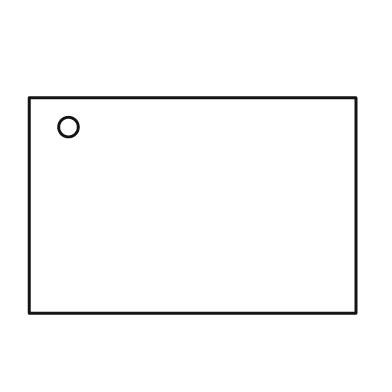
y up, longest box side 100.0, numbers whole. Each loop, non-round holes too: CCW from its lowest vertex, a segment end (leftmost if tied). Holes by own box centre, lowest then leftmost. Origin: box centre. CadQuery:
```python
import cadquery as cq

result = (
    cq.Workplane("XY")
    .moveTo(-50.0, -33.0)
    .lineTo(50.0, -33.0)
    .lineTo(50.0, 33.0)
    .lineTo(-50.0, 33.0)
    .close()
    .moveTo(-38.0, 24.0)
    .circle(3.0)
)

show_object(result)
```